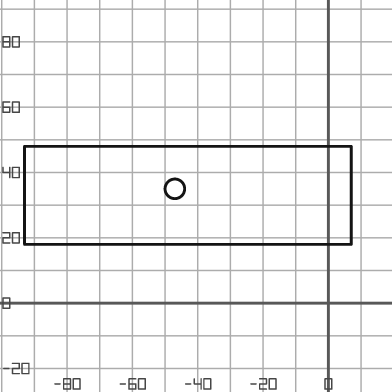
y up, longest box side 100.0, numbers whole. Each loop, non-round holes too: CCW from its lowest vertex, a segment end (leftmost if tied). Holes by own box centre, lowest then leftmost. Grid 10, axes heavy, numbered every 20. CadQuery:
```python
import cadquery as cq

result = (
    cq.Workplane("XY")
    .moveTo(-93.0, 18.0)
    .lineTo(7.0, 18.0)
    .lineTo(7.0, 48.0)
    .lineTo(-93.0, 48.0)
    .close()
    .moveTo(-47.0, 35.0)
    .circle(3.0)
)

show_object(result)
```